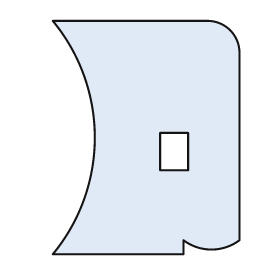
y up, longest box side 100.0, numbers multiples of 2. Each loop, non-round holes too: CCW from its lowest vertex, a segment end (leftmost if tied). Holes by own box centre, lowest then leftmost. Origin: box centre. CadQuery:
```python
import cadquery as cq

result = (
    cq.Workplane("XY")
    .moveTo(-40.0, -50.0)
    .lineTo(16.0, -50.0)
    .lineTo(16.0, -44.0)
    .threePointArc((28.0, -48.0), (40.0, -44.0))
    .lineTo(40.0, 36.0)
    .threePointArc((36.0, 46.0), (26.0, 50.0))
    .lineTo(-40.0, 50.0)
    .threePointArc((-22.0, 0.0), (-40.0, -50.0))
    .close()
    .moveTo(6.0, -14.0)
    .lineTo(18.0, -14.0)
    .lineTo(18.0, 2.0)
    .lineTo(6.0, 2.0)
    .close()
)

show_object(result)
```